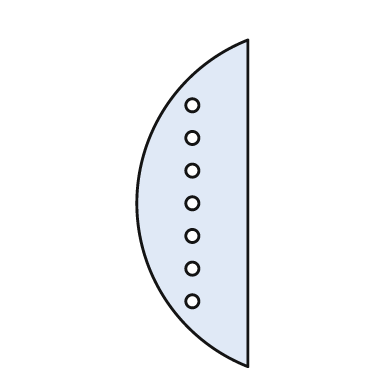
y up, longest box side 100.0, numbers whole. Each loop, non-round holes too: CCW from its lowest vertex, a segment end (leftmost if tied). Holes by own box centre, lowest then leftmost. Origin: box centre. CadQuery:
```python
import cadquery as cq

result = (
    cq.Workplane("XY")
    .moveTo(17.0, -50.0)
    .lineTo(17.0, 50.0)
    .threePointArc((-17.0, 0.0), (17.0, -50.0))
    .close()
    .moveTo(0.0, -30.0)
    .circle(2.0)
    .moveTo(0.0, -20.0)
    .circle(2.0)
    .moveTo(0.0, -10.0)
    .circle(2.0)
    .moveTo(0.0, 0.0)
    .circle(2.0)
    .moveTo(0.0, 10.0)
    .circle(2.0)
    .moveTo(0.0, 20.0)
    .circle(2.0)
    .moveTo(0.0, 30.0)
    .circle(2.0)
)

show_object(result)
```